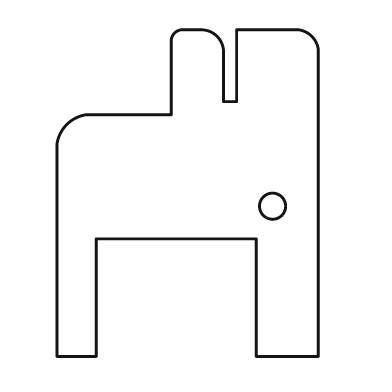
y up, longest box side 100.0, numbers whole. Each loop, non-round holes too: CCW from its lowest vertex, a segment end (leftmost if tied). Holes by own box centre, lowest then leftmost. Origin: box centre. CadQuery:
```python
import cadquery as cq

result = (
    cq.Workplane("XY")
    .moveTo(-40.0, -50.0)
    .lineTo(-28.0, -50.0)
    .lineTo(-28.0, -14.0)
    .lineTo(21.0, -14.0)
    .lineTo(21.0, -50.0)
    .lineTo(40.0, -50.0)
    .lineTo(40.0, 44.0)
    .threePointArc((38.0, 48.0), (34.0, 50.0))
    .lineTo(15.0, 50.0)
    .lineTo(15.0, 28.0)
    .lineTo(11.0, 28.0)
    .lineTo(11.0, 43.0)
    .threePointArc((9.0, 48.0), (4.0, 50.0))
    .lineTo(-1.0, 50.0)
    .threePointArc((-4.0, 49.0), (-5.0, 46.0))
    .lineTo(-5.0, 24.0)
    .lineTo(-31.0, 24.0)
    .threePointArc((-37.0, 21.0), (-40.0, 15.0))
    .close()
    .moveTo(26.0, -4.0)
    .circle(4.0)
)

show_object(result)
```